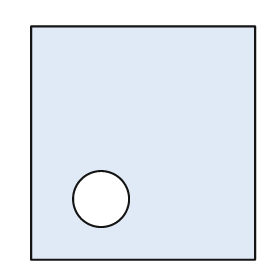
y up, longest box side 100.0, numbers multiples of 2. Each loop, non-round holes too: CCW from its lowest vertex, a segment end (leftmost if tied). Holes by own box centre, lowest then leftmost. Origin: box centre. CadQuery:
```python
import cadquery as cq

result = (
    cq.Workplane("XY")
    .moveTo(-48.0, -50.0)
    .lineTo(48.0, -50.0)
    .lineTo(48.0, 50.0)
    .lineTo(-48.0, 50.0)
    .close()
    .moveTo(-18.0, -24.0)
    .circle(12.0)
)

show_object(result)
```